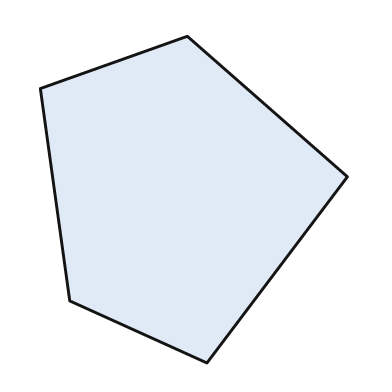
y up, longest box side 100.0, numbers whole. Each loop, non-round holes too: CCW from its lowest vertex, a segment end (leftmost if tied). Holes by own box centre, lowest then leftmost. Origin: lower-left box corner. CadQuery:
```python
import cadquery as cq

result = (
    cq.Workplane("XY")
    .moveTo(51.0, 0.0)
    .lineTo(94.0, 57.0)
    .lineTo(45.0, 100.0)
    .lineTo(0.0, 84.0)
    .lineTo(9.0, 19.0)
    .close()
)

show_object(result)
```